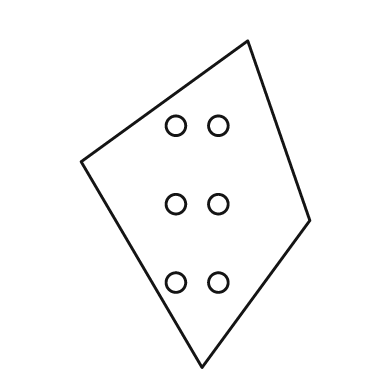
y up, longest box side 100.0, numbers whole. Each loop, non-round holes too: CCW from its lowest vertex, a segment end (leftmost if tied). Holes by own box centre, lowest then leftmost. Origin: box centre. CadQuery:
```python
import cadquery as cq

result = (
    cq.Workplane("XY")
    .moveTo(2.0, -50.0)
    .lineTo(35.0, -5.0)
    .lineTo(16.0, 50.0)
    .lineTo(-35.0, 13.0)
    .close()
    .moveTo(-6.0, -24.0)
    .circle(3.0)
    .moveTo(7.0, -24.0)
    .circle(3.0)
    .moveTo(-6.0, 0.0)
    .circle(3.0)
    .moveTo(7.0, 0.0)
    .circle(3.0)
    .moveTo(-6.0, 24.0)
    .circle(3.0)
    .moveTo(7.0, 24.0)
    .circle(3.0)
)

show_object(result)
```